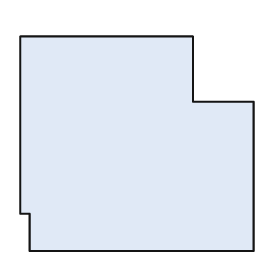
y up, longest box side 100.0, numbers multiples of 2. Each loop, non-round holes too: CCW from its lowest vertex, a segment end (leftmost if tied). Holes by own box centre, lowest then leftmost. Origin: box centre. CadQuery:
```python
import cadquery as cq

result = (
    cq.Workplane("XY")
    .moveTo(-46.0, -46.0)
    .lineTo(50.0, -46.0)
    .lineTo(50.0, 18.0)
    .lineTo(24.0, 18.0)
    .lineTo(24.0, 46.0)
    .lineTo(-50.0, 46.0)
    .lineTo(-50.0, -30.0)
    .lineTo(-46.0, -30.0)
    .close()
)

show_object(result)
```